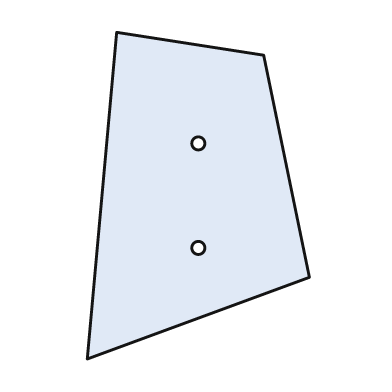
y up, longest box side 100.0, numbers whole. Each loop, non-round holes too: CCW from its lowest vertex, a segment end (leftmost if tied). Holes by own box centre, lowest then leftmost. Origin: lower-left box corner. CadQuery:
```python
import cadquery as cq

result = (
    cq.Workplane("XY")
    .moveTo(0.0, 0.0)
    .lineTo(68.0, 25.0)
    .lineTo(54.0, 93.0)
    .lineTo(9.0, 100.0)
    .close()
    .moveTo(34.0, 34.0)
    .circle(2.0)
    .moveTo(34.0, 66.0)
    .circle(2.0)
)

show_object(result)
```